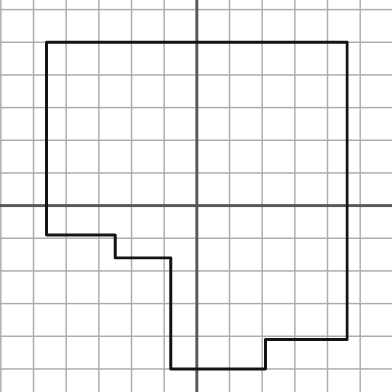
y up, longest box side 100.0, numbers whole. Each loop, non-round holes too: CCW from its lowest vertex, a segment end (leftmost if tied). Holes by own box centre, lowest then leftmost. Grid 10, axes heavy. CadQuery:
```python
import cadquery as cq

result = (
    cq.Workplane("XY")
    .moveTo(-8.0, -50.0)
    .lineTo(21.0, -50.0)
    .lineTo(21.0, -41.0)
    .lineTo(46.0, -41.0)
    .lineTo(46.0, 50.0)
    .lineTo(-46.0, 50.0)
    .lineTo(-46.0, -9.0)
    .lineTo(-25.0, -9.0)
    .lineTo(-25.0, -16.0)
    .lineTo(-8.0, -16.0)
    .close()
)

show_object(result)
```